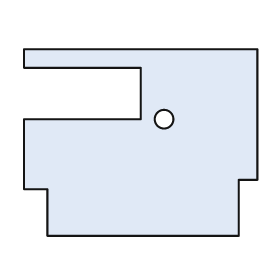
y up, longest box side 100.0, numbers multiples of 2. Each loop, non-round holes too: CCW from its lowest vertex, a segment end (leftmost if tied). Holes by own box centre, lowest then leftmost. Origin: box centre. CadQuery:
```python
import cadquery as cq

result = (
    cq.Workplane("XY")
    .moveTo(-40.0, -40.0)
    .lineTo(42.0, -40.0)
    .lineTo(42.0, -16.0)
    .lineTo(50.0, -16.0)
    .lineTo(50.0, 40.0)
    .lineTo(-50.0, 40.0)
    .lineTo(-50.0, 32.0)
    .lineTo(0.0, 32.0)
    .lineTo(0.0, 10.0)
    .lineTo(-50.0, 10.0)
    .lineTo(-50.0, -20.0)
    .lineTo(-40.0, -20.0)
    .close()
    .moveTo(10.0, 10.0)
    .circle(4.0)
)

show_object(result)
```